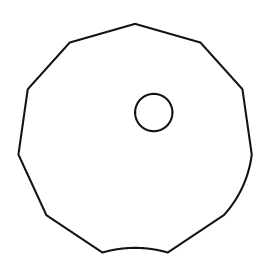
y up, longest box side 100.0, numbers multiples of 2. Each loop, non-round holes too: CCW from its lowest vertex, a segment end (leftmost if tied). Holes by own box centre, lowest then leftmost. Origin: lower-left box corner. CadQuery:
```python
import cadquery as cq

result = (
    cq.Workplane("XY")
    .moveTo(36.0, 0.0)
    .threePointArc((50.0, 2.0), (64.0, 0.0))
    .lineTo(88.0, 16.0)
    .threePointArc((96.0, 28.0), (100.0, 42.0))
    .lineTo(96.0, 70.0)
    .lineTo(78.0, 90.0)
    .lineTo(50.0, 98.0)
    .lineTo(22.0, 90.0)
    .lineTo(4.0, 70.0)
    .lineTo(0.0, 42.0)
    .lineTo(12.0, 16.0)
    .close()
    .moveTo(58.0, 60.0)
    .circle(8.0)
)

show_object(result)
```